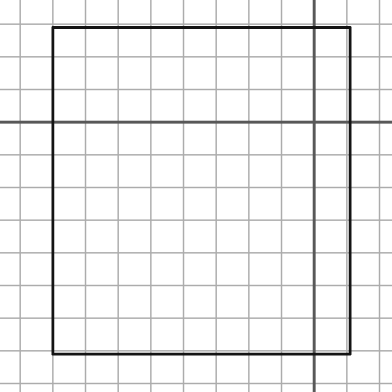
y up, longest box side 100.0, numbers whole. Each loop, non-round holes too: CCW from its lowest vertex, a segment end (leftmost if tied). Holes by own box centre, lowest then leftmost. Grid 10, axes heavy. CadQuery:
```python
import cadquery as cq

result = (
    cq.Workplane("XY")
    .moveTo(-80.0, -71.0)
    .lineTo(11.0, -71.0)
    .lineTo(11.0, 29.0)
    .lineTo(-80.0, 29.0)
    .close()
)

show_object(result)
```